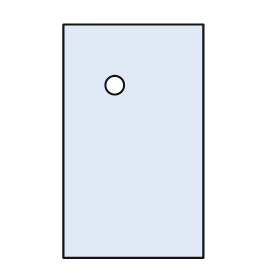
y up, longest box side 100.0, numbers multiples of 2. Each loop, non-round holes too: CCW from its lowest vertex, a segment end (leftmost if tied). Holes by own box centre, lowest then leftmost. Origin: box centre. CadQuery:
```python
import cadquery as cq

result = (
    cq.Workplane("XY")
    .moveTo(-30.0, -50.0)
    .lineTo(30.0, -50.0)
    .lineTo(30.0, 50.0)
    .lineTo(-30.0, 50.0)
    .close()
    .moveTo(-8.0, 24.0)
    .circle(4.0)
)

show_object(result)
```